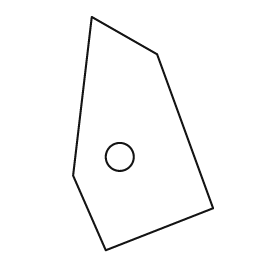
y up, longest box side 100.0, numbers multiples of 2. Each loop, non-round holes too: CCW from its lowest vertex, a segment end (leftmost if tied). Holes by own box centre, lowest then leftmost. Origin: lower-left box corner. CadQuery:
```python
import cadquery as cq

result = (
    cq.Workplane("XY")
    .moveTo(14.0, 0.0)
    .lineTo(60.0, 18.0)
    .lineTo(36.0, 84.0)
    .lineTo(8.0, 100.0)
    .lineTo(0.0, 32.0)
    .close()
    .moveTo(20.0, 40.0)
    .circle(6.0)
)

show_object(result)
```